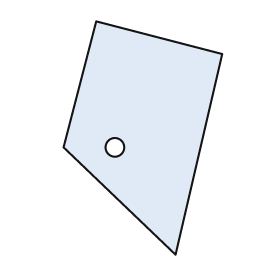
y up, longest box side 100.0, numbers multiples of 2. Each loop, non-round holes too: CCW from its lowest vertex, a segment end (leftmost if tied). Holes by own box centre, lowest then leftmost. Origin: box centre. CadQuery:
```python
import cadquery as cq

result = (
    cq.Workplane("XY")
    .moveTo(14.0, -50.0)
    .lineTo(34.0, 36.0)
    .lineTo(-20.0, 50.0)
    .lineTo(-34.0, -4.0)
    .close()
    .moveTo(-12.0, -4.0)
    .circle(4.0)
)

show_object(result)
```